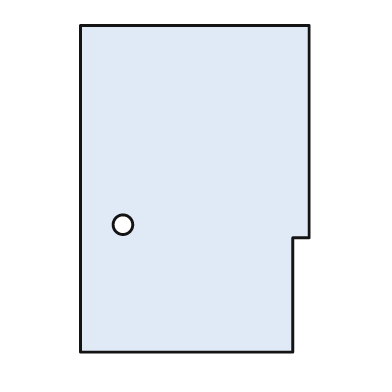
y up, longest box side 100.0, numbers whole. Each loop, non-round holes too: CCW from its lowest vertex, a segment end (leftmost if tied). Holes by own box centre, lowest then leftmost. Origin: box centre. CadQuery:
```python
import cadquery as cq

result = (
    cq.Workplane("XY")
    .moveTo(-35.0, -50.0)
    .lineTo(30.0, -50.0)
    .lineTo(30.0, -15.0)
    .lineTo(35.0, -15.0)
    .lineTo(35.0, 50.0)
    .lineTo(-35.0, 50.0)
    .close()
    .moveTo(-22.0, -11.0)
    .circle(3.0)
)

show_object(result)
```